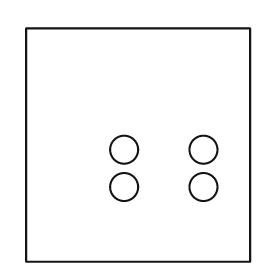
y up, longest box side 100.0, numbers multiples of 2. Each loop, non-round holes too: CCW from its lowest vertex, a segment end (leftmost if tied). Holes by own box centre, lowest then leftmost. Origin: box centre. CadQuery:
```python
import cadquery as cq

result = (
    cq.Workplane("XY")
    .moveTo(-48.0, -50.0)
    .lineTo(48.0, -50.0)
    .lineTo(48.0, 50.0)
    .lineTo(-48.0, 50.0)
    .close()
    .moveTo(-6.0, -18.0)
    .circle(6.0)
    .moveTo(28.0, -18.0)
    .circle(6.0)
    .moveTo(-6.0, -2.0)
    .circle(6.0)
    .moveTo(28.0, -2.0)
    .circle(6.0)
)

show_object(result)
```